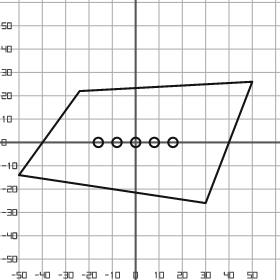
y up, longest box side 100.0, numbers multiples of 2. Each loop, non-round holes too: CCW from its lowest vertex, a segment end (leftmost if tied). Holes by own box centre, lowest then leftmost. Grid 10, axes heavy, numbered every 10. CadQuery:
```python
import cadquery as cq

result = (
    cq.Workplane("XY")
    .moveTo(30.0, -26.0)
    .lineTo(50.0, 26.0)
    .lineTo(-24.0, 22.0)
    .lineTo(-50.0, -14.0)
    .close()
    .moveTo(-16.0, 0.0)
    .circle(2.0)
    .moveTo(-8.0, 0.0)
    .circle(2.0)
    .moveTo(0.0, 0.0)
    .circle(2.0)
    .moveTo(8.0, 0.0)
    .circle(2.0)
    .moveTo(16.0, 0.0)
    .circle(2.0)
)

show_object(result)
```